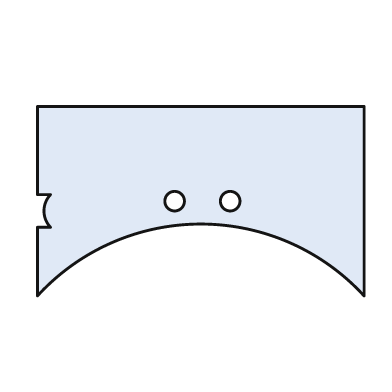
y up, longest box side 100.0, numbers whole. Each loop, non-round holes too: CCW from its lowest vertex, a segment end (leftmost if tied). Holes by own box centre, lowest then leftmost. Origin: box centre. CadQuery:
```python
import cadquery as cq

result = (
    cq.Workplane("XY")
    .moveTo(-50.0, -29.0)
    .threePointArc((0.0, -7.0), (50.0, -29.0))
    .lineTo(50.0, 29.0)
    .lineTo(-50.0, 29.0)
    .lineTo(-50.0, 2.0)
    .lineTo(-46.0, 2.0)
    .threePointArc((-48.0, -3.0), (-46.0, -8.0))
    .lineTo(-50.0, -8.0)
    .close()
    .moveTo(-8.0, 0.0)
    .circle(3.0)
    .moveTo(9.0, 0.0)
    .circle(3.0)
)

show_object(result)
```